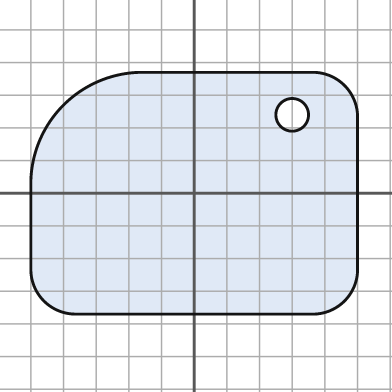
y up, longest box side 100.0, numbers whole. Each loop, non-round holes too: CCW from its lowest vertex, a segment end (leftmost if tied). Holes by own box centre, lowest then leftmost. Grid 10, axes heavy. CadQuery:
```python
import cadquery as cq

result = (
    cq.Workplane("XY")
    .moveTo(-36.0, -37.0)
    .lineTo(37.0, -37.0)
    .threePointArc((46.0, -33.0), (50.0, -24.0))
    .lineTo(50.0, 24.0)
    .threePointArc((46.0, 33.0), (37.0, 37.0))
    .lineTo(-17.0, 37.0)
    .threePointArc((-40.0, 27.0), (-50.0, 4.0))
    .lineTo(-50.0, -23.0)
    .threePointArc((-46.0, -33.0), (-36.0, -37.0))
    .close()
    .moveTo(30.0, 24.0)
    .circle(5.0)
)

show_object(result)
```